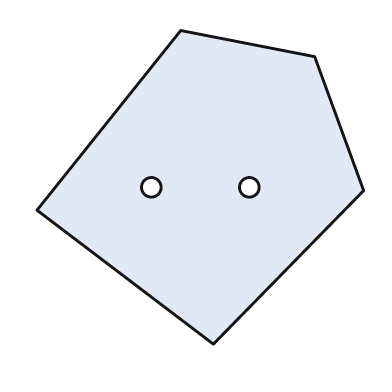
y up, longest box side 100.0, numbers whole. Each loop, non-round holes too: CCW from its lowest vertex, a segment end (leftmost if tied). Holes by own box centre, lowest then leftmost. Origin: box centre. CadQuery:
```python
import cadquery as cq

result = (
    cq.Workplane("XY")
    .moveTo(4.0, -48.0)
    .lineTo(50.0, -1.0)
    .lineTo(35.0, 40.0)
    .lineTo(-6.0, 48.0)
    .lineTo(-50.0, -7.0)
    .close()
    .moveTo(-15.0, 0.0)
    .circle(3.0)
    .moveTo(15.0, 0.0)
    .circle(3.0)
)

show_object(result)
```